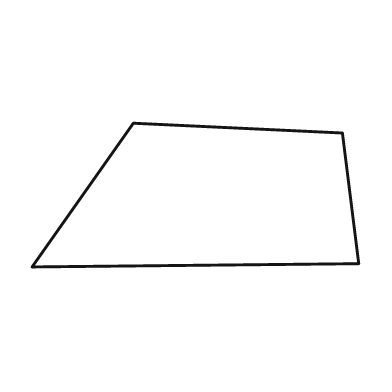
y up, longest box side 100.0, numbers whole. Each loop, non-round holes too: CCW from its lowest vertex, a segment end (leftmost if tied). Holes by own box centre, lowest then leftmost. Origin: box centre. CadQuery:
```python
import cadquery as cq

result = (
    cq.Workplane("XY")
    .moveTo(-50.0, -22.0)
    .lineTo(50.0, -21.0)
    .lineTo(45.0, 19.0)
    .lineTo(-19.0, 22.0)
    .close()
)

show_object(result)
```